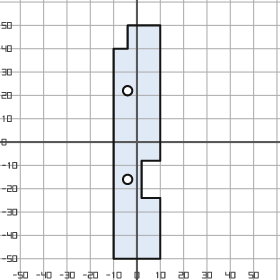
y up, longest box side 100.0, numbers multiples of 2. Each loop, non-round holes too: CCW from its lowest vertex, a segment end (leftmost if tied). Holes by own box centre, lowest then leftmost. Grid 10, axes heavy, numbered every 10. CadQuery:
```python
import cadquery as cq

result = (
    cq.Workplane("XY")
    .moveTo(-10.0, -50.0)
    .lineTo(10.0, -50.0)
    .lineTo(10.0, -24.0)
    .lineTo(2.0, -24.0)
    .lineTo(2.0, -8.0)
    .lineTo(10.0, -8.0)
    .lineTo(10.0, 50.0)
    .lineTo(-4.0, 50.0)
    .lineTo(-4.0, 40.0)
    .lineTo(-10.0, 40.0)
    .close()
    .moveTo(-4.0, -16.0)
    .circle(2.0)
    .moveTo(-4.0, 22.0)
    .circle(2.0)
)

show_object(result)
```